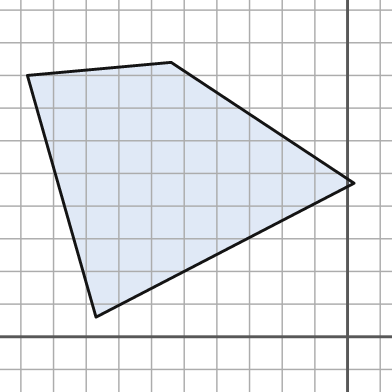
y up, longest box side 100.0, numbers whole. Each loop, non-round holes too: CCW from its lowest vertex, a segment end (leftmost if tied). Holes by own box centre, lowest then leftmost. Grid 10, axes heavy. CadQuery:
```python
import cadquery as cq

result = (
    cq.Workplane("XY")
    .moveTo(-77.0, 6.0)
    .lineTo(2.0, 47.0)
    .lineTo(-54.0, 84.0)
    .lineTo(-98.0, 80.0)
    .close()
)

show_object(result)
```